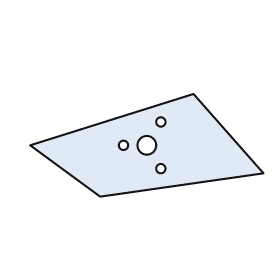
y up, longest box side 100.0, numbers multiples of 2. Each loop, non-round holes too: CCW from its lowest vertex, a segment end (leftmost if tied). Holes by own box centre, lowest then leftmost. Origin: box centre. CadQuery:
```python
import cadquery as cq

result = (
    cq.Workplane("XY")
    .moveTo(-20.0, -22.0)
    .lineTo(50.0, -12.0)
    .lineTo(20.0, 22.0)
    .lineTo(-50.0, 0.0)
    .close()
    .moveTo(6.0, -10.0)
    .circle(2.0)
    .moveTo(-10.0, 0.0)
    .circle(2.0)
    .moveTo(0.0, 0.0)
    .circle(4.0)
    .moveTo(6.0, 10.0)
    .circle(2.0)
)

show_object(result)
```